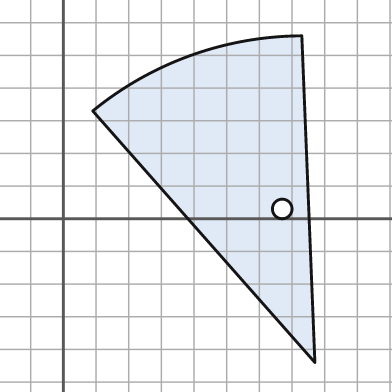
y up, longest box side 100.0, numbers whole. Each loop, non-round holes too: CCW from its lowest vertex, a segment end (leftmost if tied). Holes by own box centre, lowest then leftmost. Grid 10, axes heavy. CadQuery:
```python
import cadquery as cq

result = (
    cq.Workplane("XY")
    .moveTo(77.0, -44.0)
    .lineTo(73.0, 56.0)
    .threePointArc((39.0, 50.0), (9.0, 33.0))
    .close()
    .moveTo(67.0, 3.0)
    .circle(3.0)
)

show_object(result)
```